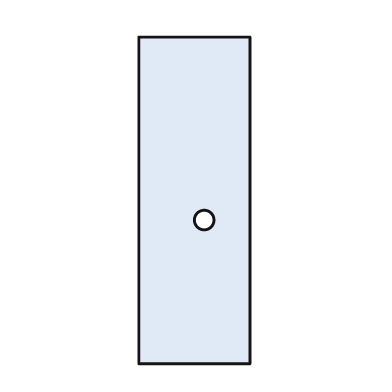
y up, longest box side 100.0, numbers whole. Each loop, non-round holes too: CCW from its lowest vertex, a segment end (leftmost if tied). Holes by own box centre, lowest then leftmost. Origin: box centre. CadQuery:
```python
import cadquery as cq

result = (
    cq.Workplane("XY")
    .moveTo(-17.0, -50.0)
    .lineTo(17.0, -50.0)
    .lineTo(17.0, 50.0)
    .lineTo(-17.0, 50.0)
    .close()
    .moveTo(3.0, -6.0)
    .circle(3.0)
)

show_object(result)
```